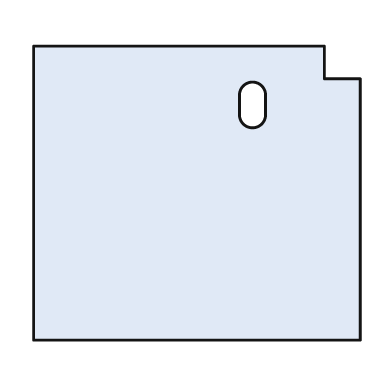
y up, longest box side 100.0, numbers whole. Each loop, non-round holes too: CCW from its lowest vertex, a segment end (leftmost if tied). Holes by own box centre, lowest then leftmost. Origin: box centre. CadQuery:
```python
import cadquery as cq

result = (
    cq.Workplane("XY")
    .moveTo(-50.0, -45.0)
    .lineTo(50.0, -45.0)
    .lineTo(50.0, 35.0)
    .lineTo(39.0, 35.0)
    .lineTo(39.0, 45.0)
    .lineTo(-50.0, 45.0)
    .close()
    .moveTo(13.0, 24.0)
    .threePointArc((17.0, 20.0), (21.0, 24.0))
    .lineTo(21.0, 30.0)
    .threePointArc((17.0, 34.0), (13.0, 30.0))
    .close()
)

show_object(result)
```